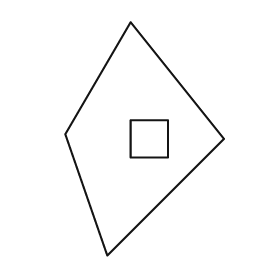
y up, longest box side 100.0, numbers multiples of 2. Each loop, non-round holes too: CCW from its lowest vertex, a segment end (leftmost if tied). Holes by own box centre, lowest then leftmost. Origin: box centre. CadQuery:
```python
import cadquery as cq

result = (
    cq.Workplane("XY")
    .moveTo(-16.0, -50.0)
    .lineTo(34.0, 0.0)
    .lineTo(-6.0, 50.0)
    .lineTo(-34.0, 2.0)
    .close()
    .moveTo(-6.0, -8.0)
    .lineTo(10.0, -8.0)
    .lineTo(10.0, 8.0)
    .lineTo(-6.0, 8.0)
    .close()
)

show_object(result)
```